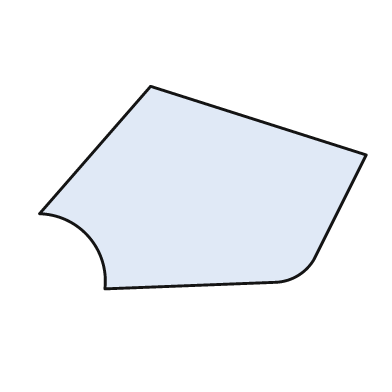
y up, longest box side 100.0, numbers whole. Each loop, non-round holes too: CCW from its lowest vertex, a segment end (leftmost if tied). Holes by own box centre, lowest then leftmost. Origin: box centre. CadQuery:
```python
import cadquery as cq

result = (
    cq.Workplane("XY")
    .moveTo(-30.0, -31.0)
    .lineTo(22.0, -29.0)
    .threePointArc((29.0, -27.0), (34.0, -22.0))
    .lineTo(50.0, 10.0)
    .lineTo(-16.0, 31.0)
    .lineTo(-50.0, -8.0)
    .threePointArc((-35.0, -15.0), (-30.0, -31.0))
    .close()
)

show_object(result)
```